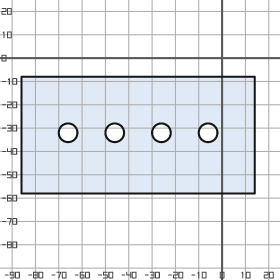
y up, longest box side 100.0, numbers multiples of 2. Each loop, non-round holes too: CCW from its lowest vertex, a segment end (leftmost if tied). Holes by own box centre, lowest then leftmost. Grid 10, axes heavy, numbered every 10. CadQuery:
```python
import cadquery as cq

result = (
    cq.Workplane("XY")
    .moveTo(-86.0, -58.0)
    .lineTo(14.0, -58.0)
    .lineTo(14.0, -8.0)
    .lineTo(-86.0, -8.0)
    .close()
    .moveTo(-66.0, -32.0)
    .circle(4.0)
    .moveTo(-46.0, -32.0)
    .circle(4.0)
    .moveTo(-26.0, -32.0)
    .circle(4.0)
    .moveTo(-6.0, -32.0)
    .circle(4.0)
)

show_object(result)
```